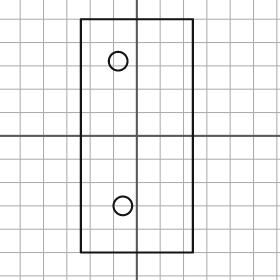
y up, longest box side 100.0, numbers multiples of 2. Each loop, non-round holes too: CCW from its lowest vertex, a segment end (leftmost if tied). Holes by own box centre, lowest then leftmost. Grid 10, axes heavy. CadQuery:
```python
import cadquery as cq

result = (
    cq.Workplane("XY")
    .moveTo(-24.0, -50.0)
    .lineTo(24.0, -50.0)
    .lineTo(24.0, 50.0)
    .lineTo(-24.0, 50.0)
    .close()
    .moveTo(-6.0, -30.0)
    .circle(4.0)
    .moveTo(-8.0, 32.0)
    .circle(4.0)
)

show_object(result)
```